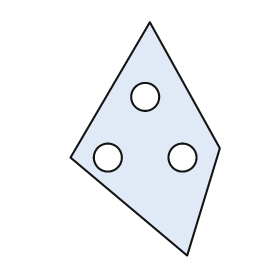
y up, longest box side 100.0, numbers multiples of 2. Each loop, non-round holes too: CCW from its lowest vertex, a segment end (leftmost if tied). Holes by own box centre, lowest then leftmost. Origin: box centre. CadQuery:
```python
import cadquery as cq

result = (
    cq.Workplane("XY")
    .moveTo(18.0, -50.0)
    .lineTo(32.0, -4.0)
    .lineTo(2.0, 50.0)
    .lineTo(-32.0, -8.0)
    .close()
    .moveTo(-16.0, -8.0)
    .circle(6.0)
    .moveTo(16.0, -8.0)
    .circle(6.0)
    .moveTo(0.0, 18.0)
    .circle(6.0)
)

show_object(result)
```